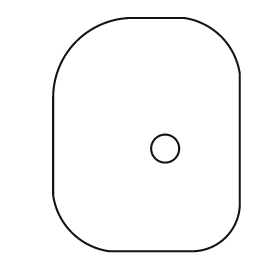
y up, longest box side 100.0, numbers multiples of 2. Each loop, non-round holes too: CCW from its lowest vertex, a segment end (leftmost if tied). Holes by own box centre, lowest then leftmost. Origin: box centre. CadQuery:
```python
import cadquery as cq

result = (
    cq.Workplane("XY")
    .moveTo(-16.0, -50.0)
    .lineTo(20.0, -50.0)
    .threePointArc((34.0, -44.0), (40.0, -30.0))
    .lineTo(40.0, 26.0)
    .threePointArc((32.0, 42.0), (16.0, 50.0))
    .lineTo(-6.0, 50.0)
    .threePointArc((-30.0, 40.0), (-40.0, 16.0))
    .lineTo(-40.0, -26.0)
    .threePointArc((-32.0, -42.0), (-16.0, -50.0))
    .close()
    .moveTo(8.0, -6.0)
    .circle(6.0)
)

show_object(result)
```